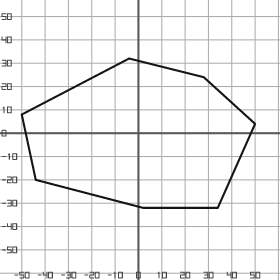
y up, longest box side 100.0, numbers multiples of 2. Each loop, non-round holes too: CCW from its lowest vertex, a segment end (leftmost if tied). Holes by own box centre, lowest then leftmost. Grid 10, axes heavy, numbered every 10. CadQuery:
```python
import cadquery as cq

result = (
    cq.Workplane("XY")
    .moveTo(2.0, -32.0)
    .lineTo(34.0, -32.0)
    .lineTo(50.0, 4.0)
    .lineTo(28.0, 24.0)
    .lineTo(-4.0, 32.0)
    .lineTo(-50.0, 8.0)
    .lineTo(-44.0, -20.0)
    .close()
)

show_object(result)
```